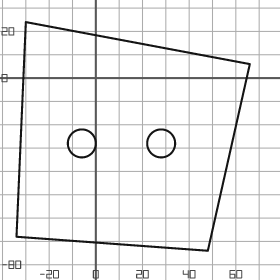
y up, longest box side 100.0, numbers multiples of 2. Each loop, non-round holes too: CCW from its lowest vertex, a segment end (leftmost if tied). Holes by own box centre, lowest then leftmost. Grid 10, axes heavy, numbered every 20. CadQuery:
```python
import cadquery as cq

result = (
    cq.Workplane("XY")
    .moveTo(48.0, -74.0)
    .lineTo(66.0, 6.0)
    .lineTo(-30.0, 24.0)
    .lineTo(-34.0, -68.0)
    .close()
    .moveTo(-6.0, -28.0)
    .circle(6.0)
    .moveTo(28.0, -28.0)
    .circle(6.0)
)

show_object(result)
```